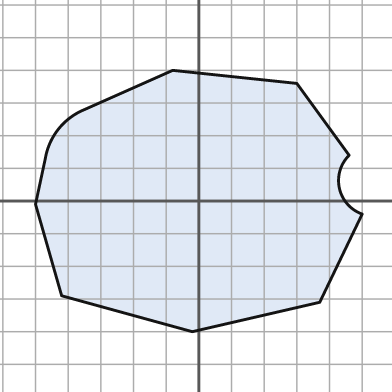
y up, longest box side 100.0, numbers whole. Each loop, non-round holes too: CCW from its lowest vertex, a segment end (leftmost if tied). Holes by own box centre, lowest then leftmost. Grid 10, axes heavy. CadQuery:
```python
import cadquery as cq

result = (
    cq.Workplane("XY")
    .moveTo(-2.0, -40.0)
    .lineTo(37.0, -31.0)
    .lineTo(50.0, -4.0)
    .threePointArc((43.0, 4.0), (46.0, 14.0))
    .lineTo(30.0, 36.0)
    .lineTo(-8.0, 40.0)
    .lineTo(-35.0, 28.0)
    .threePointArc((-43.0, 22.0), (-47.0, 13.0))
    .lineTo(-50.0, -1.0)
    .lineTo(-42.0, -29.0)
    .close()
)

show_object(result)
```